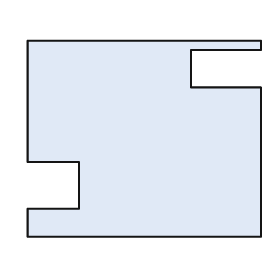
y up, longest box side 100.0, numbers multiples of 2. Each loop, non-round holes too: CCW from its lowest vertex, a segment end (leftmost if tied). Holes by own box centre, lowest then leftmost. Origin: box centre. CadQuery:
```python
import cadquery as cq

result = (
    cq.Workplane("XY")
    .moveTo(-50.0, -42.0)
    .lineTo(50.0, -42.0)
    .lineTo(50.0, 22.0)
    .lineTo(20.0, 22.0)
    .lineTo(20.0, 38.0)
    .lineTo(50.0, 38.0)
    .lineTo(50.0, 42.0)
    .lineTo(-50.0, 42.0)
    .lineTo(-50.0, -10.0)
    .lineTo(-28.0, -10.0)
    .lineTo(-28.0, -30.0)
    .lineTo(-50.0, -30.0)
    .close()
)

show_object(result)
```